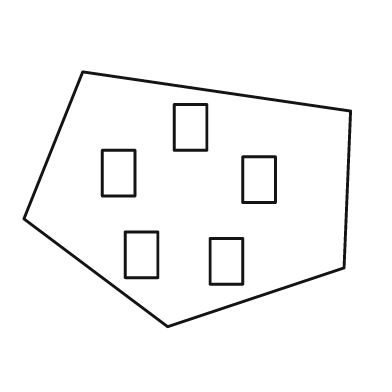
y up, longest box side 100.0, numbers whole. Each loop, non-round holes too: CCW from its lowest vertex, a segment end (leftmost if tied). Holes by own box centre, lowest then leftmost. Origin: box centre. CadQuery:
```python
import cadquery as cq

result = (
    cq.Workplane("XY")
    .moveTo(-6.0, -39.0)
    .lineTo(48.0, -21.0)
    .lineTo(50.0, 27.0)
    .lineTo(-32.0, 39.0)
    .lineTo(-50.0, -6.0)
    .close()
    .moveTo(7.0, -26.0)
    .lineTo(17.0, -26.0)
    .lineTo(17.0, -12.0)
    .lineTo(7.0, -12.0)
    .close()
    .moveTo(-19.0, -24.0)
    .lineTo(-9.0, -24.0)
    .lineTo(-9.0, -10.0)
    .lineTo(-19.0, -10.0)
    .close()
    .moveTo(17.0, -1.0)
    .lineTo(27.0, -1.0)
    .lineTo(27.0, 13.0)
    .lineTo(17.0, 13.0)
    .close()
    .moveTo(-26.0, 1.0)
    .lineTo(-16.0, 1.0)
    .lineTo(-16.0, 15.0)
    .lineTo(-26.0, 15.0)
    .close()
    .moveTo(-4.0, 15.0)
    .lineTo(6.0, 15.0)
    .lineTo(6.0, 29.0)
    .lineTo(-4.0, 29.0)
    .close()
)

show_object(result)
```